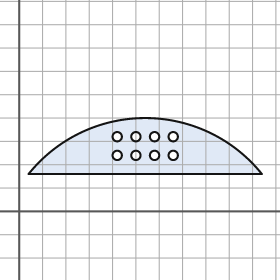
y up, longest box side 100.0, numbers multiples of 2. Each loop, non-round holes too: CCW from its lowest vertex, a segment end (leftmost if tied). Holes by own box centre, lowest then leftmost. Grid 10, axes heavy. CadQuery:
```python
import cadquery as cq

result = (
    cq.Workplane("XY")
    .moveTo(4.0, 16.0)
    .lineTo(104.0, 16.0)
    .threePointArc((54.0, 40.0), (4.0, 16.0))
    .close()
    .moveTo(42.0, 24.0)
    .circle(2.0)
    .moveTo(50.0, 24.0)
    .circle(2.0)
    .moveTo(58.0, 24.0)
    .circle(2.0)
    .moveTo(66.0, 24.0)
    .circle(2.0)
    .moveTo(42.0, 32.0)
    .circle(2.0)
    .moveTo(50.0, 32.0)
    .circle(2.0)
    .moveTo(58.0, 32.0)
    .circle(2.0)
    .moveTo(66.0, 32.0)
    .circle(2.0)
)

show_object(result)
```